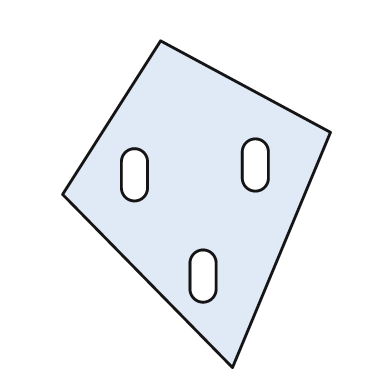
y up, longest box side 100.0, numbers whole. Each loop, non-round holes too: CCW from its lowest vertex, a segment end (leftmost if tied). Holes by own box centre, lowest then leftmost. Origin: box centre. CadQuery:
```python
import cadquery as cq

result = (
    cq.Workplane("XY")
    .moveTo(11.0, -50.0)
    .lineTo(41.0, 22.0)
    .lineTo(-11.0, 50.0)
    .lineTo(-41.0, 3.0)
    .close()
    .moveTo(-2.0, -26.0)
    .threePointArc((2.0, -30.0), (6.0, -26.0))
    .lineTo(6.0, -18.0)
    .threePointArc((2.0, -14.0), (-2.0, -18.0))
    .close()
    .moveTo(-23.0, 5.0)
    .threePointArc((-19.0, 1.0), (-15.0, 5.0))
    .lineTo(-15.0, 13.0)
    .threePointArc((-19.0, 17.0), (-23.0, 13.0))
    .close()
    .moveTo(14.0, 8.0)
    .threePointArc((18.0, 4.0), (22.0, 8.0))
    .lineTo(22.0, 16.0)
    .threePointArc((18.0, 20.0), (14.0, 16.0))
    .close()
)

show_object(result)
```